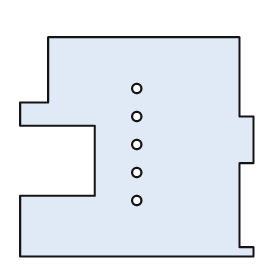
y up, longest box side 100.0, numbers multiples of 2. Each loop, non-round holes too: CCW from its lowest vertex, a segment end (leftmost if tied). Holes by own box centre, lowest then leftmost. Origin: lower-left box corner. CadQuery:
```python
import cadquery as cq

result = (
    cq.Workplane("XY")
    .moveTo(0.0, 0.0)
    .lineTo(100.0, 0.0)
    .lineTo(100.0, 4.0)
    .lineTo(94.0, 4.0)
    .lineTo(94.0, 40.0)
    .lineTo(100.0, 40.0)
    .lineTo(100.0, 60.0)
    .lineTo(94.0, 60.0)
    .lineTo(94.0, 94.0)
    .lineTo(12.0, 94.0)
    .lineTo(12.0, 66.0)
    .lineTo(0.0, 66.0)
    .lineTo(0.0, 56.0)
    .lineTo(32.0, 56.0)
    .lineTo(32.0, 26.0)
    .lineTo(0.0, 26.0)
    .close()
    .moveTo(50.0, 24.0)
    .circle(2.0)
    .moveTo(50.0, 36.0)
    .circle(2.0)
    .moveTo(50.0, 48.0)
    .circle(2.0)
    .moveTo(50.0, 60.0)
    .circle(2.0)
    .moveTo(50.0, 72.0)
    .circle(2.0)
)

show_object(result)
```